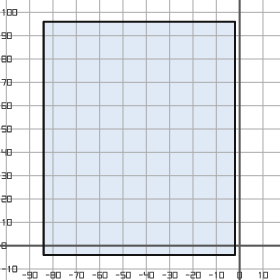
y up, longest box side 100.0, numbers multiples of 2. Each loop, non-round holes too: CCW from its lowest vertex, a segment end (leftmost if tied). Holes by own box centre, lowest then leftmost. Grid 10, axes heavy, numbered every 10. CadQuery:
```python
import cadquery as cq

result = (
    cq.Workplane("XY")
    .moveTo(-84.0, -4.0)
    .lineTo(-2.0, -4.0)
    .lineTo(-2.0, 96.0)
    .lineTo(-84.0, 96.0)
    .close()
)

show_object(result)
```